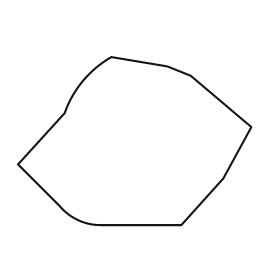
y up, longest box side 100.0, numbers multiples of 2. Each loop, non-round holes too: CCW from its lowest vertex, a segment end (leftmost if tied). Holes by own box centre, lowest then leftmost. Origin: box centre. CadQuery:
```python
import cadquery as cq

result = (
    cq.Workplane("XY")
    .moveTo(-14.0, -36.0)
    .lineTo(20.0, -36.0)
    .lineTo(38.0, -16.0)
    .lineTo(50.0, 6.0)
    .lineTo(24.0, 28.0)
    .lineTo(14.0, 32.0)
    .lineTo(-10.0, 36.0)
    .threePointArc((-22.0, 26.0), (-30.0, 12.0))
    .lineTo(-50.0, -10.0)
    .lineTo(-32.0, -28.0)
    .threePointArc((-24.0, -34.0), (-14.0, -36.0))
    .close()
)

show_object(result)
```